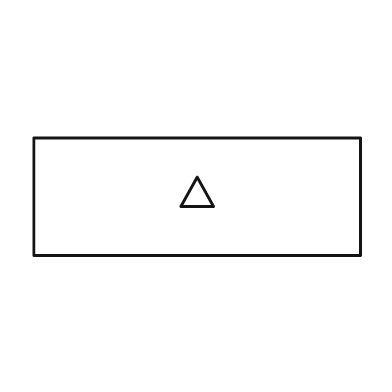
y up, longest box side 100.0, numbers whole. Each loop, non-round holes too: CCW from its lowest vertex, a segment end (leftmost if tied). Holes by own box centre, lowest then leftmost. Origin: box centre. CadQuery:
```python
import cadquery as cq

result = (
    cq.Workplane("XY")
    .moveTo(-50.0, -18.0)
    .lineTo(50.0, -18.0)
    .lineTo(50.0, 18.0)
    .lineTo(-50.0, 18.0)
    .close()
    .moveTo(-5.0, -3.0)
    .lineTo(5.0, -3.0)
    .lineTo(0.0, 6.0)
    .close()
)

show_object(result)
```